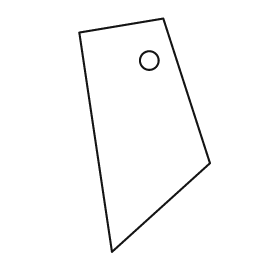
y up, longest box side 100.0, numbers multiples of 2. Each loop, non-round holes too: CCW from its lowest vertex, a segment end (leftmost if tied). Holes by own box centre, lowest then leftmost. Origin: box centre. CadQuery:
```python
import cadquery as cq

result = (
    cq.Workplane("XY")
    .moveTo(-14.0, -50.0)
    .lineTo(28.0, -12.0)
    .lineTo(8.0, 50.0)
    .lineTo(-28.0, 44.0)
    .close()
    .moveTo(2.0, 32.0)
    .circle(4.0)
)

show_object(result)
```